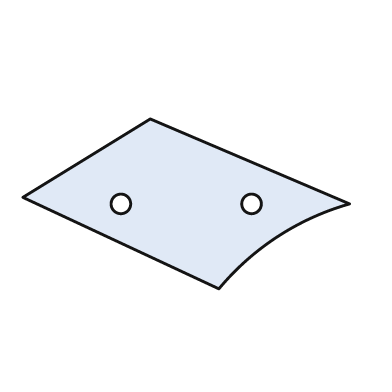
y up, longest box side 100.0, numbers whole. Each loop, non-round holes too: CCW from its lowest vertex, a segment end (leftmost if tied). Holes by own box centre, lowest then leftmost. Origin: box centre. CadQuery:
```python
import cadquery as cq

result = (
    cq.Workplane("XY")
    .moveTo(10.0, -26.0)
    .threePointArc((28.0, -10.0), (50.0, 0.0))
    .lineTo(-11.0, 26.0)
    .lineTo(-50.0, 2.0)
    .close()
    .moveTo(-20.0, 0.0)
    .circle(3.0)
    .moveTo(20.0, 0.0)
    .circle(3.0)
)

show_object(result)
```